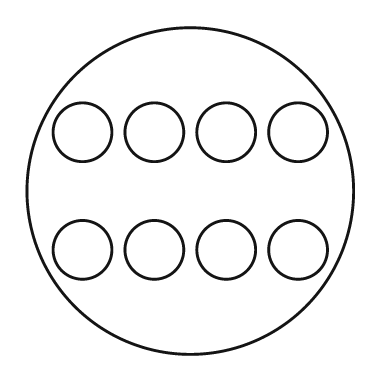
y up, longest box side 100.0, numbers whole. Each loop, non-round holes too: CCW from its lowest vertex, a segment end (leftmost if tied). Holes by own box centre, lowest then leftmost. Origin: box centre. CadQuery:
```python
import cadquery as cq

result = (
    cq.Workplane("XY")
    .moveTo(0.0, 0.0)
    .circle(50.0)
    .moveTo(-33.0, -18.0)
    .circle(9.0)
    .moveTo(-11.0, -18.0)
    .circle(9.0)
    .moveTo(11.0, -18.0)
    .circle(9.0)
    .moveTo(33.0, -18.0)
    .circle(9.0)
    .moveTo(-33.0, 18.0)
    .circle(9.0)
    .moveTo(-11.0, 18.0)
    .circle(9.0)
    .moveTo(11.0, 18.0)
    .circle(9.0)
    .moveTo(33.0, 18.0)
    .circle(9.0)
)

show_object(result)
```